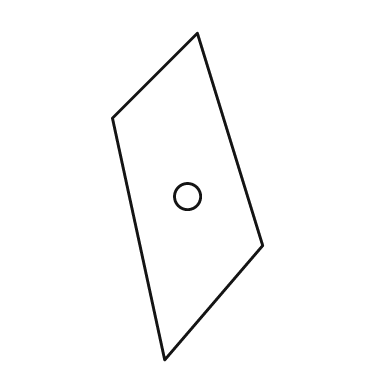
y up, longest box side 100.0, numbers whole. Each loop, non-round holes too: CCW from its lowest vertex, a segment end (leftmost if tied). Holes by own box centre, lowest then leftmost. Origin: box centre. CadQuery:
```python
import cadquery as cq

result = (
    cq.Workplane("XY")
    .moveTo(-7.0, -50.0)
    .lineTo(23.0, -15.0)
    .lineTo(3.0, 50.0)
    .lineTo(-23.0, 24.0)
    .close()
    .moveTo(0.0, 0.0)
    .circle(4.0)
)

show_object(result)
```